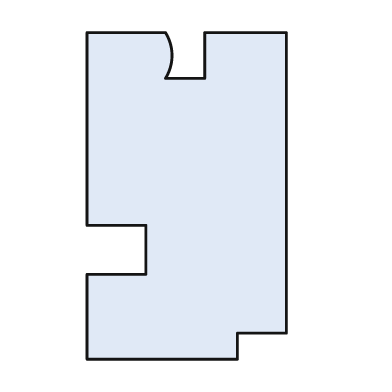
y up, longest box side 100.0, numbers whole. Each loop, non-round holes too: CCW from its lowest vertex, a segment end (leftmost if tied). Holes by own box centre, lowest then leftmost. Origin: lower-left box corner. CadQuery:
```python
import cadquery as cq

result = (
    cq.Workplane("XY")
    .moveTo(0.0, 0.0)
    .lineTo(46.0, 0.0)
    .lineTo(46.0, 8.0)
    .lineTo(61.0, 8.0)
    .lineTo(61.0, 100.0)
    .lineTo(36.0, 100.0)
    .lineTo(36.0, 86.0)
    .lineTo(24.0, 86.0)
    .threePointArc((26.0, 93.0), (24.0, 100.0))
    .lineTo(0.0, 100.0)
    .lineTo(0.0, 41.0)
    .lineTo(18.0, 41.0)
    .lineTo(18.0, 26.0)
    .lineTo(0.0, 26.0)
    .close()
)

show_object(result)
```